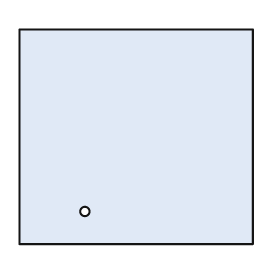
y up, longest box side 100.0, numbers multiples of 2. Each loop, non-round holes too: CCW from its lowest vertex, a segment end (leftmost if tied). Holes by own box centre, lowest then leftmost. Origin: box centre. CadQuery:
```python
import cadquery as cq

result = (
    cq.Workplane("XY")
    .moveTo(-50.0, -46.0)
    .lineTo(50.0, -46.0)
    .lineTo(50.0, 46.0)
    .lineTo(-50.0, 46.0)
    .close()
    .moveTo(-22.0, -32.0)
    .circle(2.0)
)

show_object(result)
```